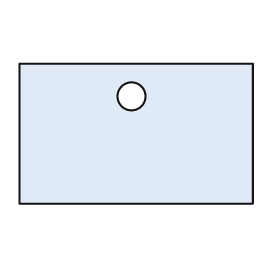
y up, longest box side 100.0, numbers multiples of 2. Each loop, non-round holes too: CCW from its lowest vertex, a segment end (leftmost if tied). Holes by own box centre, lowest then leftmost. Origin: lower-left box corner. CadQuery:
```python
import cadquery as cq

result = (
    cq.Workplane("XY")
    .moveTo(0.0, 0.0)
    .lineTo(100.0, 0.0)
    .lineTo(100.0, 60.0)
    .lineTo(0.0, 60.0)
    .close()
    .moveTo(48.0, 46.0)
    .circle(6.0)
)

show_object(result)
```